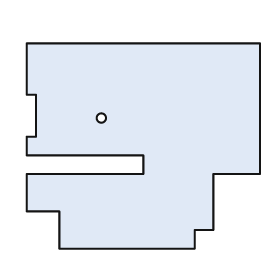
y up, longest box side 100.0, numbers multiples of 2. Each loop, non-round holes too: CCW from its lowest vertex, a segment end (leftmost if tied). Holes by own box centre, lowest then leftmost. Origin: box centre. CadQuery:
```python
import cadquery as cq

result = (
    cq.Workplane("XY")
    .moveTo(-36.0, -44.0)
    .lineTo(22.0, -44.0)
    .lineTo(22.0, -36.0)
    .lineTo(30.0, -36.0)
    .lineTo(30.0, -12.0)
    .lineTo(50.0, -12.0)
    .lineTo(50.0, 44.0)
    .lineTo(-50.0, 44.0)
    .lineTo(-50.0, 22.0)
    .lineTo(-46.0, 22.0)
    .lineTo(-46.0, 4.0)
    .lineTo(-50.0, 4.0)
    .lineTo(-50.0, -4.0)
    .lineTo(0.0, -4.0)
    .lineTo(0.0, -12.0)
    .lineTo(-50.0, -12.0)
    .lineTo(-50.0, -28.0)
    .lineTo(-36.0, -28.0)
    .close()
    .moveTo(-18.0, 12.0)
    .circle(2.0)
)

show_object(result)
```